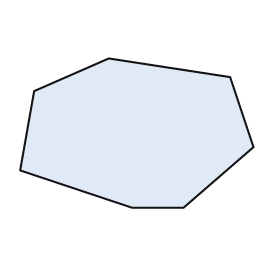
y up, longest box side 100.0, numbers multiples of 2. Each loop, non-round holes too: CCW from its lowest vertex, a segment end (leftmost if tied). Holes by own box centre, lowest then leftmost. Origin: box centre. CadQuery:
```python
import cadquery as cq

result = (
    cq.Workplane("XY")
    .moveTo(-2.0, -32.0)
    .lineTo(20.0, -32.0)
    .lineTo(50.0, -6.0)
    .lineTo(40.0, 24.0)
    .lineTo(-12.0, 32.0)
    .lineTo(-44.0, 18.0)
    .lineTo(-50.0, -16.0)
    .close()
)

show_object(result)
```